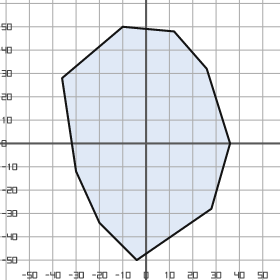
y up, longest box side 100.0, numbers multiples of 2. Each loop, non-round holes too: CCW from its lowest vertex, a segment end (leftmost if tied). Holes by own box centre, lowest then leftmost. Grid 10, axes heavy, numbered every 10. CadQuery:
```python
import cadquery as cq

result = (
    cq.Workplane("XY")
    .moveTo(-4.0, -50.0)
    .lineTo(28.0, -28.0)
    .lineTo(36.0, 0.0)
    .lineTo(26.0, 32.0)
    .lineTo(12.0, 48.0)
    .lineTo(-10.0, 50.0)
    .lineTo(-36.0, 28.0)
    .lineTo(-30.0, -12.0)
    .lineTo(-20.0, -34.0)
    .close()
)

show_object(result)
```